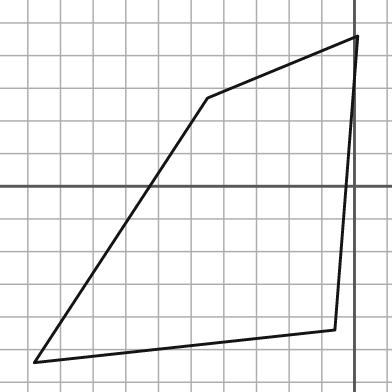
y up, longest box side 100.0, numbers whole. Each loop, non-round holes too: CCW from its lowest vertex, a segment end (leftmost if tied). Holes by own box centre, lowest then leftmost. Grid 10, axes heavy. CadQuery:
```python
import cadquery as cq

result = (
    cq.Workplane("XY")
    .moveTo(-98.0, -54.0)
    .lineTo(-6.0, -44.0)
    .lineTo(1.0, 46.0)
    .lineTo(-45.0, 27.0)
    .close()
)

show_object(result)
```